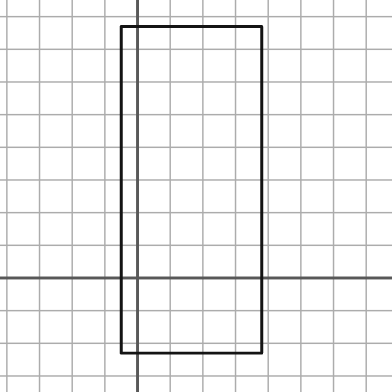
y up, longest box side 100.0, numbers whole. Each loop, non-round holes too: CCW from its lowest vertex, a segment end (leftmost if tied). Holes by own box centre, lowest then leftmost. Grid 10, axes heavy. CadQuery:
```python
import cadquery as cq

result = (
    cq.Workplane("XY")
    .moveTo(-5.0, -23.0)
    .lineTo(38.0, -23.0)
    .lineTo(38.0, 77.0)
    .lineTo(-5.0, 77.0)
    .close()
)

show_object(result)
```